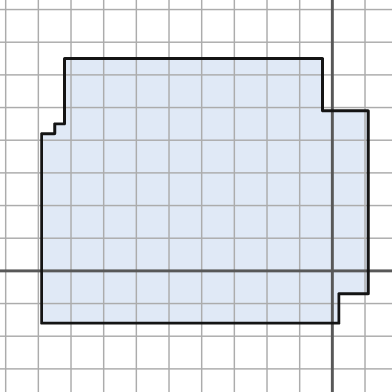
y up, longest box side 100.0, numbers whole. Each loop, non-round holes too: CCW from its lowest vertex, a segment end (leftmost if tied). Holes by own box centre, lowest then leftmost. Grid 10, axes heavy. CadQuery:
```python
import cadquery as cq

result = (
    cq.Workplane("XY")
    .moveTo(-89.0, -16.0)
    .lineTo(2.0, -16.0)
    .lineTo(2.0, -7.0)
    .lineTo(11.0, -7.0)
    .lineTo(11.0, 49.0)
    .lineTo(-3.0, 49.0)
    .lineTo(-3.0, 65.0)
    .lineTo(-82.0, 65.0)
    .lineTo(-82.0, 45.0)
    .lineTo(-85.0, 45.0)
    .lineTo(-85.0, 42.0)
    .lineTo(-89.0, 42.0)
    .close()
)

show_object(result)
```